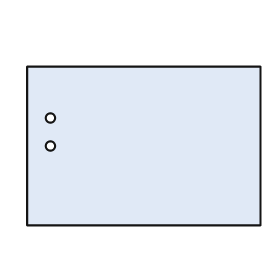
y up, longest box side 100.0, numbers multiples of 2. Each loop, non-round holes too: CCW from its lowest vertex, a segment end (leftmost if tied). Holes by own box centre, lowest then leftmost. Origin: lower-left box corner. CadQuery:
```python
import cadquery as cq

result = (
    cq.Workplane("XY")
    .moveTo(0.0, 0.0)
    .lineTo(100.0, 0.0)
    .lineTo(100.0, 68.0)
    .lineTo(0.0, 68.0)
    .close()
    .moveTo(10.0, 34.0)
    .circle(2.0)
    .moveTo(10.0, 46.0)
    .circle(2.0)
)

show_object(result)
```